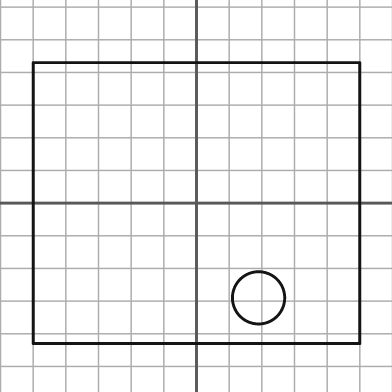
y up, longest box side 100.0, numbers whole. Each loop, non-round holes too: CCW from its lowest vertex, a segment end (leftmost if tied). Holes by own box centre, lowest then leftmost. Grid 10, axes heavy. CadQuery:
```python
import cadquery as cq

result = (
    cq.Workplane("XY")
    .moveTo(-50.0, -43.0)
    .lineTo(50.0, -43.0)
    .lineTo(50.0, 43.0)
    .lineTo(-50.0, 43.0)
    .close()
    .moveTo(19.0, -29.0)
    .circle(8.0)
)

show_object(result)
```